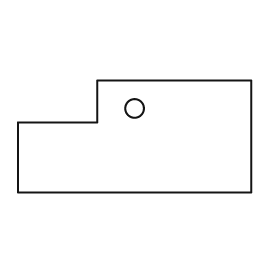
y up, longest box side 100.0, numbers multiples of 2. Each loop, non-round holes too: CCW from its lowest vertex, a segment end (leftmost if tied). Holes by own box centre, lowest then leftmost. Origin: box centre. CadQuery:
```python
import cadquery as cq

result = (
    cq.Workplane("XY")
    .moveTo(-50.0, -24.0)
    .lineTo(50.0, -24.0)
    .lineTo(50.0, 24.0)
    .lineTo(-16.0, 24.0)
    .lineTo(-16.0, 6.0)
    .lineTo(-50.0, 6.0)
    .close()
    .moveTo(0.0, 12.0)
    .circle(4.0)
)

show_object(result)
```